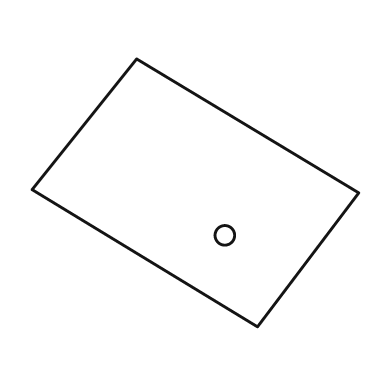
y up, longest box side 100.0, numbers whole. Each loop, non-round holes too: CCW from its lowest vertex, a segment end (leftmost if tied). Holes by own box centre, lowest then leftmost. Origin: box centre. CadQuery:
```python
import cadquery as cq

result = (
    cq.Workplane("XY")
    .moveTo(19.0, -41.0)
    .lineTo(50.0, 0.0)
    .lineTo(-18.0, 41.0)
    .lineTo(-50.0, 1.0)
    .close()
    .moveTo(9.0, -13.0)
    .circle(3.0)
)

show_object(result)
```